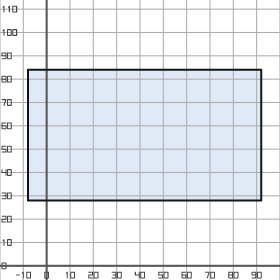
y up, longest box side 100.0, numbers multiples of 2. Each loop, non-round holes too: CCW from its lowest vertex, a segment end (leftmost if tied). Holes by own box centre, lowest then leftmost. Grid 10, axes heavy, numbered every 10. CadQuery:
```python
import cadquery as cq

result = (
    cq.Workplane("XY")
    .moveTo(-8.0, 28.0)
    .lineTo(92.0, 28.0)
    .lineTo(92.0, 84.0)
    .lineTo(-8.0, 84.0)
    .close()
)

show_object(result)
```